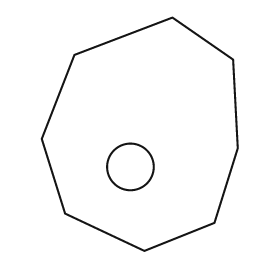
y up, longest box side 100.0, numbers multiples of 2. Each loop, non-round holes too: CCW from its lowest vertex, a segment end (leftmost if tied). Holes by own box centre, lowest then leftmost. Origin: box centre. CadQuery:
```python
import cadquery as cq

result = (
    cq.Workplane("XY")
    .moveTo(2.0, -50.0)
    .lineTo(32.0, -38.0)
    .lineTo(42.0, -6.0)
    .lineTo(40.0, 32.0)
    .lineTo(14.0, 50.0)
    .lineTo(-28.0, 34.0)
    .lineTo(-42.0, -2.0)
    .lineTo(-32.0, -34.0)
    .close()
    .moveTo(-4.0, -14.0)
    .circle(10.0)
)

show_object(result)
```